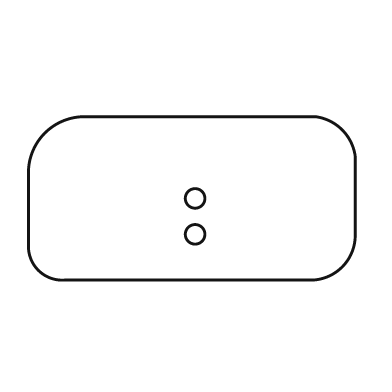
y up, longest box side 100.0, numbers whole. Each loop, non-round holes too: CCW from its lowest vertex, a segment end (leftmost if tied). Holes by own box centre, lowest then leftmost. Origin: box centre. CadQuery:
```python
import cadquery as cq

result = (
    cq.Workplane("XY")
    .moveTo(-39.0, -25.0)
    .lineTo(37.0, -25.0)
    .threePointArc((46.0, -21.0), (50.0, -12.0))
    .lineTo(50.0, 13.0)
    .threePointArc((46.0, 21.0), (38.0, 25.0))
    .lineTo(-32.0, 25.0)
    .threePointArc((-45.0, 20.0), (-50.0, 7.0))
    .lineTo(-50.0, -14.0)
    .threePointArc((-47.0, -22.0), (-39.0, -25.0))
    .close()
    .moveTo(1.0, -11.0)
    .circle(3.0)
    .moveTo(1.0, 0.0)
    .circle(3.0)
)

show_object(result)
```